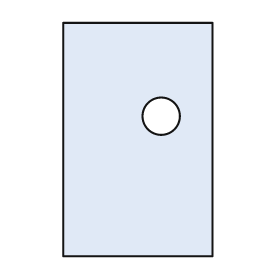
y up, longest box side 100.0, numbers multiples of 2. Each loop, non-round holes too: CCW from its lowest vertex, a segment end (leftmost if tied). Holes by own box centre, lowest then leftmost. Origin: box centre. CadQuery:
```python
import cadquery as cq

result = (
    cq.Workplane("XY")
    .moveTo(-32.0, -50.0)
    .lineTo(32.0, -50.0)
    .lineTo(32.0, 50.0)
    .lineTo(-32.0, 50.0)
    .close()
    .moveTo(10.0, 10.0)
    .circle(8.0)
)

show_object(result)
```